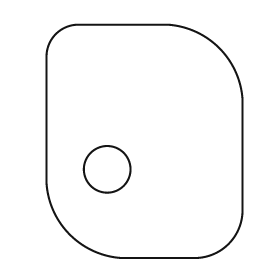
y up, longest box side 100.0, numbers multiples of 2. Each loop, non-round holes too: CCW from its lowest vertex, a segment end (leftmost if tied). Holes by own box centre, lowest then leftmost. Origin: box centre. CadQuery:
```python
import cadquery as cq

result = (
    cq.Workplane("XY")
    .moveTo(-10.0, -50.0)
    .lineTo(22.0, -50.0)
    .threePointArc((36.0, -44.0), (42.0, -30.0))
    .lineTo(42.0, 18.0)
    .threePointArc((32.0, 40.0), (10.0, 50.0))
    .lineTo(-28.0, 50.0)
    .threePointArc((-38.0, 46.0), (-42.0, 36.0))
    .lineTo(-42.0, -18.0)
    .threePointArc((-32.0, -40.0), (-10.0, -50.0))
    .close()
    .moveTo(-16.0, -12.0)
    .circle(10.0)
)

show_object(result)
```